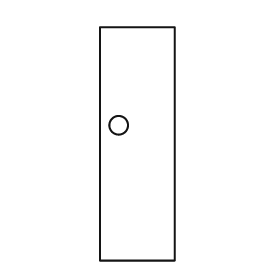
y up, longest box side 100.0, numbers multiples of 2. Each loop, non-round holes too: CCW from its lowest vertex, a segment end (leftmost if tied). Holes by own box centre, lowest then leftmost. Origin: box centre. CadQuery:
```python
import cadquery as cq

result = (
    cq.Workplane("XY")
    .moveTo(-16.0, -50.0)
    .lineTo(16.0, -50.0)
    .lineTo(16.0, 50.0)
    .lineTo(-16.0, 50.0)
    .close()
    .moveTo(-8.0, 8.0)
    .circle(4.0)
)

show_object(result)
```